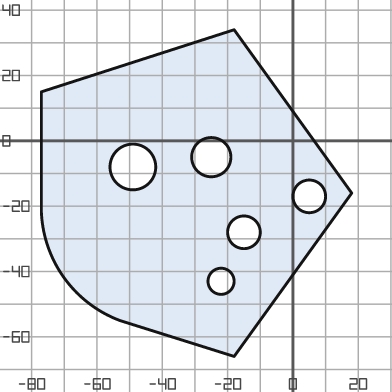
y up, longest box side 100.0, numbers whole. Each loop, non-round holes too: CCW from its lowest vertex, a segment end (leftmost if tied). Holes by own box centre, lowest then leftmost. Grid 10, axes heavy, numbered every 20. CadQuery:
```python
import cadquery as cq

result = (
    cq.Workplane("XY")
    .moveTo(-18.0, -66.0)
    .lineTo(18.0, -16.0)
    .lineTo(-18.0, 34.0)
    .lineTo(-77.0, 15.0)
    .lineTo(-77.0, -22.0)
    .threePointArc((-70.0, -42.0), (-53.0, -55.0))
    .close()
    .moveTo(-22.0, -43.0)
    .circle(4.0)
    .moveTo(-15.0, -28.0)
    .circle(5.0)
    .moveTo(5.0, -17.0)
    .circle(5.0)
    .moveTo(-49.0, -8.0)
    .circle(7.0)
    .moveTo(-25.0, -5.0)
    .circle(6.0)
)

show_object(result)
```